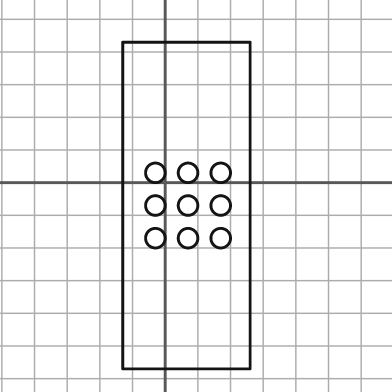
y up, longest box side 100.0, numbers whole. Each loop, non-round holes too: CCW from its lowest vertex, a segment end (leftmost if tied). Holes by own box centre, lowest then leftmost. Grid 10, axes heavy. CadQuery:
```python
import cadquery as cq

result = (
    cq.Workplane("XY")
    .moveTo(-13.0, -57.0)
    .lineTo(26.0, -57.0)
    .lineTo(26.0, 43.0)
    .lineTo(-13.0, 43.0)
    .close()
    .moveTo(-3.0, -17.0)
    .circle(3.0)
    .moveTo(7.0, -17.0)
    .circle(3.0)
    .moveTo(17.0, -17.0)
    .circle(3.0)
    .moveTo(-3.0, -7.0)
    .circle(3.0)
    .moveTo(7.0, -7.0)
    .circle(3.0)
    .moveTo(17.0, -7.0)
    .circle(3.0)
    .moveTo(-3.0, 3.0)
    .circle(3.0)
    .moveTo(7.0, 3.0)
    .circle(3.0)
    .moveTo(17.0, 3.0)
    .circle(3.0)
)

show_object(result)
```